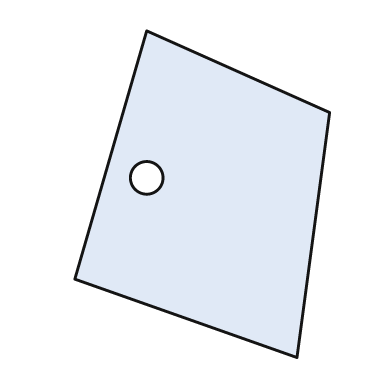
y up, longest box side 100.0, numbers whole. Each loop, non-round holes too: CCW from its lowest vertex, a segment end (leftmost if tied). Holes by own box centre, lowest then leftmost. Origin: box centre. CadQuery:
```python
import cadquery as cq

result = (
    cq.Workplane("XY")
    .moveTo(29.0, -50.0)
    .lineTo(39.0, 25.0)
    .lineTo(-17.0, 50.0)
    .lineTo(-39.0, -26.0)
    .close()
    .moveTo(-17.0, 5.0)
    .circle(5.0)
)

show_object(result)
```